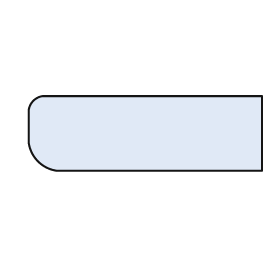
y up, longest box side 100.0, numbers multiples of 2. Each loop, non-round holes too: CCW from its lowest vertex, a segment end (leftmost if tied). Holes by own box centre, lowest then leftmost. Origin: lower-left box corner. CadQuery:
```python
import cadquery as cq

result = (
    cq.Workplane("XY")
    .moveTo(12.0, 0.0)
    .lineTo(100.0, 0.0)
    .lineTo(100.0, 32.0)
    .lineTo(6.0, 32.0)
    .threePointArc((2.0, 30.0), (0.0, 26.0))
    .lineTo(0.0, 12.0)
    .threePointArc((4.0, 4.0), (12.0, 0.0))
    .close()
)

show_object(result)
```